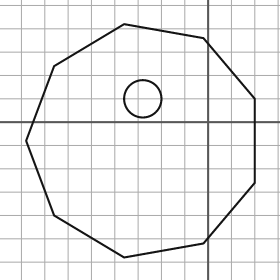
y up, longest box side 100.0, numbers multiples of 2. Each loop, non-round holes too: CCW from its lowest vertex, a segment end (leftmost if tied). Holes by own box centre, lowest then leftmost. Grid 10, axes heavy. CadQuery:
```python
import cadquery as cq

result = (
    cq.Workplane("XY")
    .moveTo(-36.0, -58.0)
    .lineTo(-2.0, -52.0)
    .lineTo(20.0, -26.0)
    .lineTo(20.0, 10.0)
    .lineTo(-2.0, 36.0)
    .lineTo(-36.0, 42.0)
    .lineTo(-66.0, 24.0)
    .lineTo(-78.0, -8.0)
    .lineTo(-66.0, -40.0)
    .close()
    .moveTo(-28.0, 10.0)
    .circle(8.0)
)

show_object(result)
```